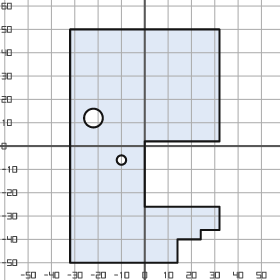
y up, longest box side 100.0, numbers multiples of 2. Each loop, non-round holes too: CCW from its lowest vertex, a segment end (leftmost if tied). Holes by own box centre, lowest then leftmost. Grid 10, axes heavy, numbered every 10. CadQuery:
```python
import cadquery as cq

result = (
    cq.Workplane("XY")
    .moveTo(-32.0, -50.0)
    .lineTo(14.0, -50.0)
    .lineTo(14.0, -40.0)
    .lineTo(24.0, -40.0)
    .lineTo(24.0, -36.0)
    .lineTo(32.0, -36.0)
    .lineTo(32.0, -26.0)
    .lineTo(0.0, -26.0)
    .lineTo(0.0, 2.0)
    .lineTo(32.0, 2.0)
    .lineTo(32.0, 50.0)
    .lineTo(-32.0, 50.0)
    .close()
    .moveTo(-10.0, -6.0)
    .circle(2.0)
    .moveTo(-22.0, 12.0)
    .circle(4.0)
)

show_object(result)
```